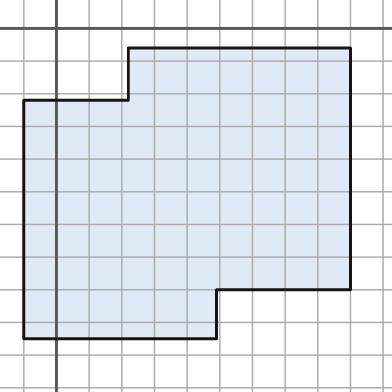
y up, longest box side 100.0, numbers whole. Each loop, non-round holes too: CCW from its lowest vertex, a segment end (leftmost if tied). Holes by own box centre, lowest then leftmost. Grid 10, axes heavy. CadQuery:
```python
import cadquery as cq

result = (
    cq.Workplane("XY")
    .moveTo(-10.0, -95.0)
    .lineTo(49.0, -95.0)
    .lineTo(49.0, -80.0)
    .lineTo(90.0, -80.0)
    .lineTo(90.0, -6.0)
    .lineTo(22.0, -6.0)
    .lineTo(22.0, -22.0)
    .lineTo(-10.0, -22.0)
    .close()
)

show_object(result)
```